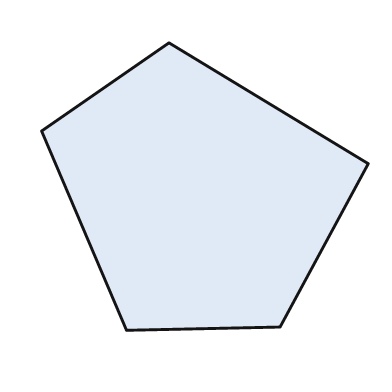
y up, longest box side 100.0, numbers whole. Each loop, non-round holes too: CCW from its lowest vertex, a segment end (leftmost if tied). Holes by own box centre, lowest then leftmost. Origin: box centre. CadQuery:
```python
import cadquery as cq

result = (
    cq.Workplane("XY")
    .moveTo(-24.0, -44.0)
    .lineTo(23.0, -43.0)
    .lineTo(50.0, 7.0)
    .lineTo(-11.0, 44.0)
    .lineTo(-50.0, 17.0)
    .close()
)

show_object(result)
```